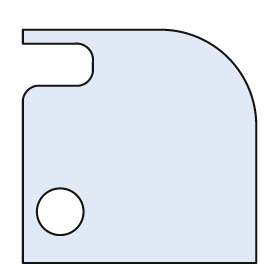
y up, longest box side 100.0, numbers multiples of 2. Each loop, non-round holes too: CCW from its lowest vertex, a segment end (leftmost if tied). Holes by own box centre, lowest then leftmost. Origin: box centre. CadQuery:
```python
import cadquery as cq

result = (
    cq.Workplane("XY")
    .moveTo(-50.0, -50.0)
    .lineTo(50.0, -50.0)
    .lineTo(50.0, 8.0)
    .threePointArc((38.0, 38.0), (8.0, 50.0))
    .lineTo(-50.0, 50.0)
    .lineTo(-50.0, 44.0)
    .lineTo(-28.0, 44.0)
    .threePointArc((-22.0, 42.0), (-20.0, 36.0))
    .lineTo(-20.0, 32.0)
    .threePointArc((-22.0, 28.0), (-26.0, 26.0))
    .lineTo(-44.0, 26.0)
    .threePointArc((-48.0, 24.0), (-50.0, 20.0))
    .close()
    .moveTo(-34.0, -28.0)
    .circle(10.0)
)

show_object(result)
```